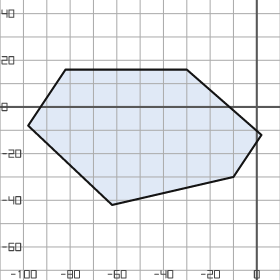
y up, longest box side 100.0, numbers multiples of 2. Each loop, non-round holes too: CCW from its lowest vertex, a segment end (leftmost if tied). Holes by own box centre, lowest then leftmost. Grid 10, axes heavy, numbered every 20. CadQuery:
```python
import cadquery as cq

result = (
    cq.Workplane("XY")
    .moveTo(-62.0, -42.0)
    .lineTo(-10.0, -30.0)
    .lineTo(2.0, -12.0)
    .lineTo(-30.0, 16.0)
    .lineTo(-82.0, 16.0)
    .lineTo(-98.0, -8.0)
    .close()
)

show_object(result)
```